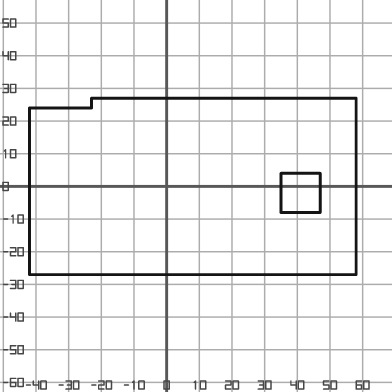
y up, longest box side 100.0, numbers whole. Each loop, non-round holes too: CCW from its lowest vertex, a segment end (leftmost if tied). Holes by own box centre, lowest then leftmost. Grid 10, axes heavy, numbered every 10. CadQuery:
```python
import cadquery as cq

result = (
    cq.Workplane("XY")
    .moveTo(-42.0, -27.0)
    .lineTo(58.0, -27.0)
    .lineTo(58.0, 27.0)
    .lineTo(-23.0, 27.0)
    .lineTo(-23.0, 24.0)
    .lineTo(-42.0, 24.0)
    .close()
    .moveTo(35.0, -8.0)
    .lineTo(47.0, -8.0)
    .lineTo(47.0, 4.0)
    .lineTo(35.0, 4.0)
    .close()
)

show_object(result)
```